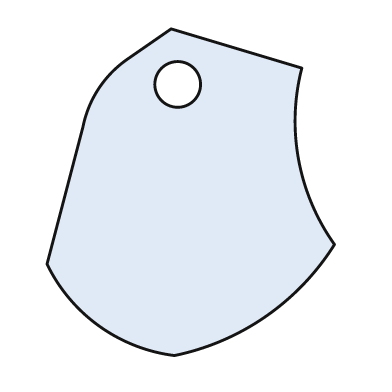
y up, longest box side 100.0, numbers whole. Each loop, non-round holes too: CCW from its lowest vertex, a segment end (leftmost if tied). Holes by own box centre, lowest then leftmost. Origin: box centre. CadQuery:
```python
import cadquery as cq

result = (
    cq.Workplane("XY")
    .moveTo(-5.0, -50.0)
    .threePointArc((23.0, -38.0), (44.0, -16.0))
    .threePointArc((33.0, 10.0), (34.0, 38.0))
    .lineTo(-6.0, 50.0)
    .lineTo(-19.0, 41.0)
    .threePointArc((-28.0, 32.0), (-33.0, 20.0))
    .lineTo(-44.0, -22.0)
    .threePointArc((-28.0, -41.0), (-5.0, -50.0))
    .close()
    .moveTo(-4.0, 33.0)
    .circle(7.0)
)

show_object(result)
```